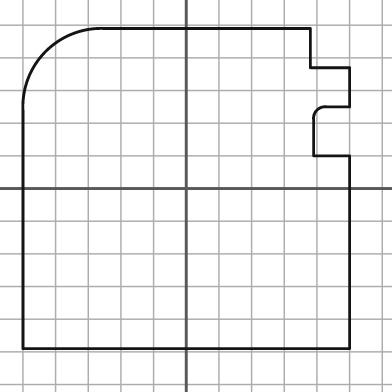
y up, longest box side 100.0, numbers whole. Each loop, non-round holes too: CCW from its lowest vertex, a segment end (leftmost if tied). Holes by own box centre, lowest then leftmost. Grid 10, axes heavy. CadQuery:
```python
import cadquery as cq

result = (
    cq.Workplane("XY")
    .moveTo(-50.0, -49.0)
    .lineTo(50.0, -49.0)
    .lineTo(50.0, 10.0)
    .lineTo(39.0, 10.0)
    .lineTo(39.0, 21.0)
    .threePointArc((40.0, 24.0), (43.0, 25.0))
    .lineTo(50.0, 25.0)
    .lineTo(50.0, 37.0)
    .lineTo(38.0, 37.0)
    .lineTo(38.0, 49.0)
    .lineTo(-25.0, 49.0)
    .threePointArc((-43.0, 42.0), (-50.0, 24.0))
    .close()
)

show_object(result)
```